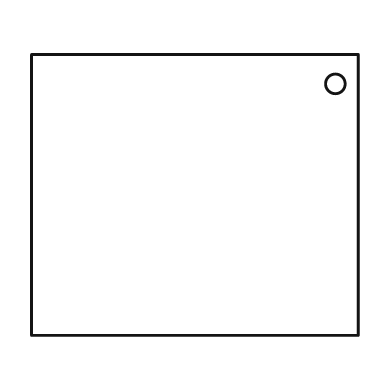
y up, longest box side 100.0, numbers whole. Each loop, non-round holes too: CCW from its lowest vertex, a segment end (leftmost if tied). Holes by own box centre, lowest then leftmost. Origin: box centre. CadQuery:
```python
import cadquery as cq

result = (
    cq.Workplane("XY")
    .moveTo(-50.0, -43.0)
    .lineTo(50.0, -43.0)
    .lineTo(50.0, 43.0)
    .lineTo(-50.0, 43.0)
    .close()
    .moveTo(43.0, 34.0)
    .circle(3.0)
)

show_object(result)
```